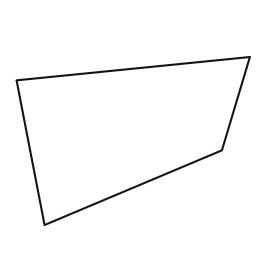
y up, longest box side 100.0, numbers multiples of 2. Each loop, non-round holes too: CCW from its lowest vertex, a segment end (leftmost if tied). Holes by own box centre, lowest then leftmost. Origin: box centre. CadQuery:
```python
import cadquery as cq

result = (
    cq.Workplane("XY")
    .moveTo(-38.0, -36.0)
    .lineTo(38.0, -4.0)
    .lineTo(50.0, 36.0)
    .lineTo(-50.0, 26.0)
    .close()
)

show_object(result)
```